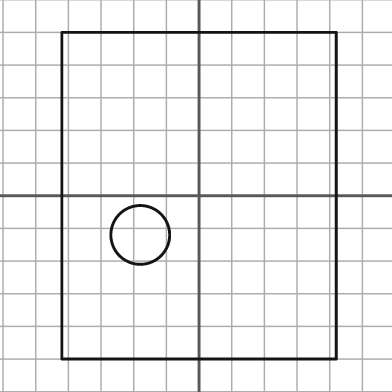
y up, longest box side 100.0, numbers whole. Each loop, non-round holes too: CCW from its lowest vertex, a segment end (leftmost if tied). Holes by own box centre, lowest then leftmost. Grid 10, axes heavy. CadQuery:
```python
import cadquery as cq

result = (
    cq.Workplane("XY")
    .moveTo(-42.0, -50.0)
    .lineTo(42.0, -50.0)
    .lineTo(42.0, 50.0)
    .lineTo(-42.0, 50.0)
    .close()
    .moveTo(-18.0, -12.0)
    .circle(9.0)
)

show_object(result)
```